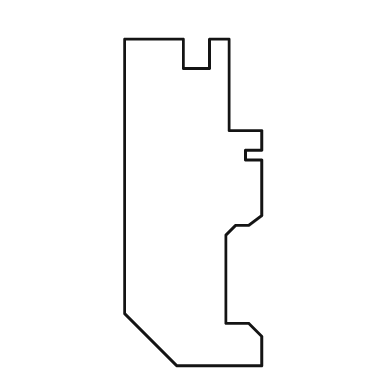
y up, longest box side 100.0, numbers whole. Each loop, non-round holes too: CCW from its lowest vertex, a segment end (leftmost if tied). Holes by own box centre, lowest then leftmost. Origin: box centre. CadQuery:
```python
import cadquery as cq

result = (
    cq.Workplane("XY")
    .moveTo(-5.0, -50.0)
    .lineTo(21.0, -50.0)
    .lineTo(21.0, -41.0)
    .lineTo(17.0, -37.0)
    .lineTo(10.0, -37.0)
    .lineTo(10.0, -10.0)
    .lineTo(13.0, -7.0)
    .lineTo(17.0, -7.0)
    .lineTo(21.0, -4.0)
    .lineTo(21.0, 13.0)
    .lineTo(16.0, 13.0)
    .lineTo(16.0, 16.0)
    .lineTo(21.0, 16.0)
    .lineTo(21.0, 22.0)
    .lineTo(11.0, 22.0)
    .lineTo(11.0, 50.0)
    .lineTo(5.0, 50.0)
    .lineTo(5.0, 41.0)
    .lineTo(-3.0, 41.0)
    .lineTo(-3.0, 50.0)
    .lineTo(-21.0, 50.0)
    .lineTo(-21.0, -34.0)
    .close()
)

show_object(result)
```